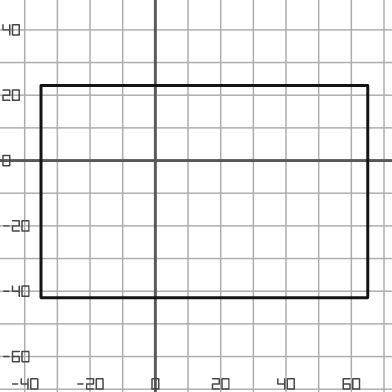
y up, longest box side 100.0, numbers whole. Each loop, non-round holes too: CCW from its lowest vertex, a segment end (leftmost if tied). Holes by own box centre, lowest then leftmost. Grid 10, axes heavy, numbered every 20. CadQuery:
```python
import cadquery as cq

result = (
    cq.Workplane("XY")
    .moveTo(-35.0, -42.0)
    .lineTo(65.0, -42.0)
    .lineTo(65.0, 23.0)
    .lineTo(-35.0, 23.0)
    .close()
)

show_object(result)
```